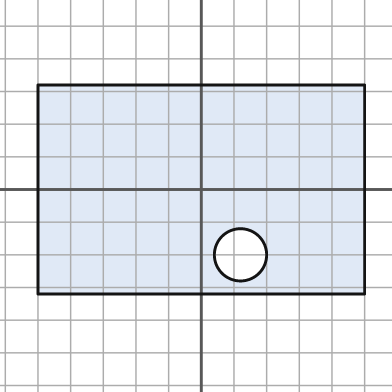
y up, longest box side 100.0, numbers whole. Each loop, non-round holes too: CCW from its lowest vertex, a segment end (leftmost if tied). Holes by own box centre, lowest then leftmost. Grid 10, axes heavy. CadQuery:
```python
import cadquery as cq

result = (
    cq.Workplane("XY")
    .moveTo(-50.0, -32.0)
    .lineTo(50.0, -32.0)
    .lineTo(50.0, 32.0)
    .lineTo(-50.0, 32.0)
    .close()
    .moveTo(12.0, -20.0)
    .circle(8.0)
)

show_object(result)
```